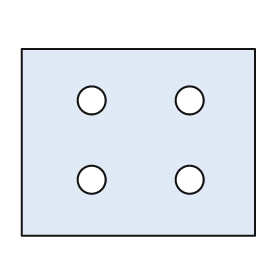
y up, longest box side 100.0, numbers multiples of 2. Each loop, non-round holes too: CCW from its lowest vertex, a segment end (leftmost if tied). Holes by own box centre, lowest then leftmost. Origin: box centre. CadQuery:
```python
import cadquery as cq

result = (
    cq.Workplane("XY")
    .moveTo(-50.0, -40.0)
    .lineTo(50.0, -40.0)
    .lineTo(50.0, 40.0)
    .lineTo(-50.0, 40.0)
    .close()
    .moveTo(-20.0, -16.0)
    .circle(6.0)
    .moveTo(22.0, -16.0)
    .circle(6.0)
    .moveTo(-20.0, 18.0)
    .circle(6.0)
    .moveTo(22.0, 18.0)
    .circle(6.0)
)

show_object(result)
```